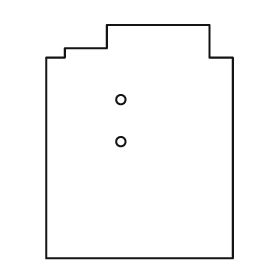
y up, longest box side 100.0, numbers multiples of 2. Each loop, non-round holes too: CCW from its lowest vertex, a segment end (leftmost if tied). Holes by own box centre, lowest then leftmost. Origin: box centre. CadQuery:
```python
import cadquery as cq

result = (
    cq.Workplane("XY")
    .moveTo(-40.0, -50.0)
    .lineTo(40.0, -50.0)
    .lineTo(40.0, 36.0)
    .lineTo(30.0, 36.0)
    .lineTo(30.0, 50.0)
    .lineTo(-14.0, 50.0)
    .lineTo(-14.0, 40.0)
    .lineTo(-32.0, 40.0)
    .lineTo(-32.0, 36.0)
    .lineTo(-40.0, 36.0)
    .close()
    .moveTo(-8.0, 0.0)
    .circle(2.0)
    .moveTo(-8.0, 18.0)
    .circle(2.0)
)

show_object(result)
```